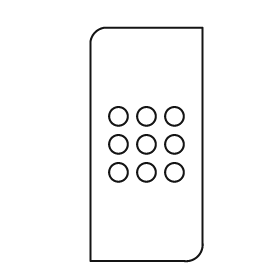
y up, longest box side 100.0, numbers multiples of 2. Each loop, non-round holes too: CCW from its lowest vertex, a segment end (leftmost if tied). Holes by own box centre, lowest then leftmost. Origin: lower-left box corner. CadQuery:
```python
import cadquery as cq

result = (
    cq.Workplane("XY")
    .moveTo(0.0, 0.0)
    .lineTo(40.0, 0.0)
    .threePointArc((46.0, 2.0), (48.0, 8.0))
    .lineTo(48.0, 100.0)
    .lineTo(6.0, 100.0)
    .threePointArc((2.0, 98.0), (0.0, 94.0))
    .close()
    .moveTo(12.0, 38.0)
    .circle(4.0)
    .moveTo(24.0, 38.0)
    .circle(4.0)
    .moveTo(36.0, 38.0)
    .circle(4.0)
    .moveTo(12.0, 50.0)
    .circle(4.0)
    .moveTo(24.0, 50.0)
    .circle(4.0)
    .moveTo(36.0, 50.0)
    .circle(4.0)
    .moveTo(12.0, 62.0)
    .circle(4.0)
    .moveTo(24.0, 62.0)
    .circle(4.0)
    .moveTo(36.0, 62.0)
    .circle(4.0)
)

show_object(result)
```